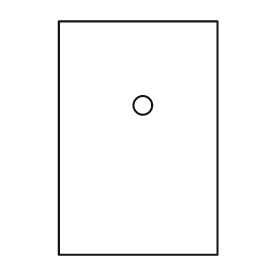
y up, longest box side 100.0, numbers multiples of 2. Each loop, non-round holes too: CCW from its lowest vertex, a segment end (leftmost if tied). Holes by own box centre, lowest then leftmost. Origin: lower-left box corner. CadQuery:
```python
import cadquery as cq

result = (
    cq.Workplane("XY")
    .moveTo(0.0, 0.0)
    .lineTo(68.0, 0.0)
    .lineTo(68.0, 100.0)
    .lineTo(0.0, 100.0)
    .close()
    .moveTo(36.0, 64.0)
    .circle(4.0)
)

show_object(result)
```